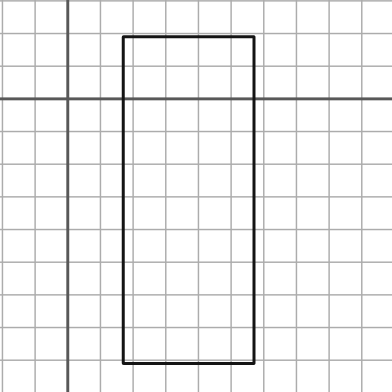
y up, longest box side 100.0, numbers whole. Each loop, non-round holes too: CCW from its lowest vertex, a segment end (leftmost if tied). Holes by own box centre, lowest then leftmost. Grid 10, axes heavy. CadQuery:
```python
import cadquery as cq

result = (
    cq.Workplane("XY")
    .moveTo(17.0, -81.0)
    .lineTo(57.0, -81.0)
    .lineTo(57.0, 19.0)
    .lineTo(17.0, 19.0)
    .close()
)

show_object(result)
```